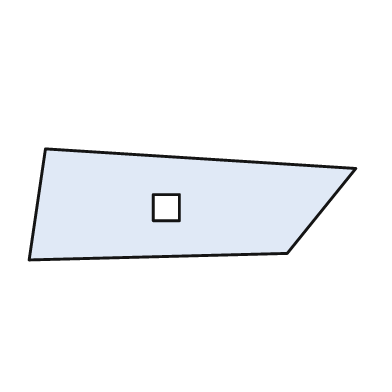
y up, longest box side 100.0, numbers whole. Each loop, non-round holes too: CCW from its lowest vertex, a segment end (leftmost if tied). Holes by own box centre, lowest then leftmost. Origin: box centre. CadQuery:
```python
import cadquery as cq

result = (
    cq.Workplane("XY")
    .moveTo(-50.0, -17.0)
    .lineTo(29.0, -15.0)
    .lineTo(50.0, 11.0)
    .lineTo(-45.0, 17.0)
    .close()
    .moveTo(-12.0, -5.0)
    .lineTo(-4.0, -5.0)
    .lineTo(-4.0, 3.0)
    .lineTo(-12.0, 3.0)
    .close()
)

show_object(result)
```